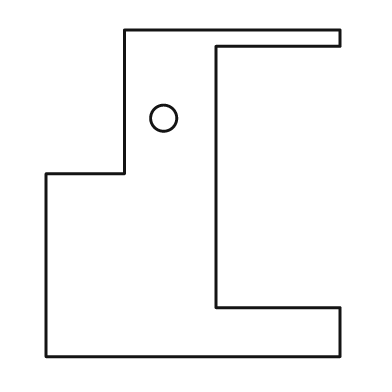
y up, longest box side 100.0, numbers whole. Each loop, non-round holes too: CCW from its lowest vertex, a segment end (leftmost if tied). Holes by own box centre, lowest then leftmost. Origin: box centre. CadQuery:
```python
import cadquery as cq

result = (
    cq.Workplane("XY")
    .moveTo(-45.0, -50.0)
    .lineTo(45.0, -50.0)
    .lineTo(45.0, -35.0)
    .lineTo(7.0, -35.0)
    .lineTo(7.0, 45.0)
    .lineTo(45.0, 45.0)
    .lineTo(45.0, 50.0)
    .lineTo(-21.0, 50.0)
    .lineTo(-21.0, 6.0)
    .lineTo(-45.0, 6.0)
    .close()
    .moveTo(-9.0, 23.0)
    .circle(4.0)
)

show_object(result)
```